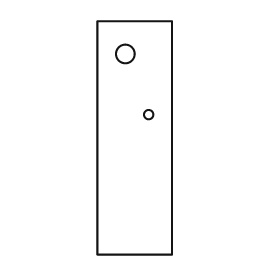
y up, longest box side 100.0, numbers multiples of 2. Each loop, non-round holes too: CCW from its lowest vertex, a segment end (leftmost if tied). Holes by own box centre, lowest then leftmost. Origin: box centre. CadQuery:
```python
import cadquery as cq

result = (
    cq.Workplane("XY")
    .moveTo(-16.0, -50.0)
    .lineTo(16.0, -50.0)
    .lineTo(16.0, 50.0)
    .lineTo(-16.0, 50.0)
    .close()
    .moveTo(6.0, 10.0)
    .circle(2.0)
    .moveTo(-4.0, 36.0)
    .circle(4.0)
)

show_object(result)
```